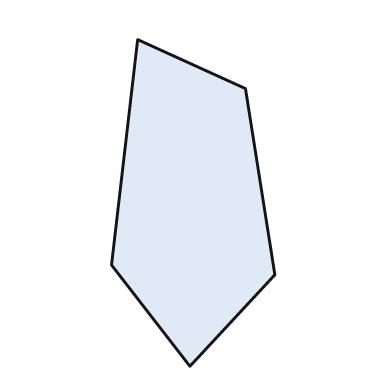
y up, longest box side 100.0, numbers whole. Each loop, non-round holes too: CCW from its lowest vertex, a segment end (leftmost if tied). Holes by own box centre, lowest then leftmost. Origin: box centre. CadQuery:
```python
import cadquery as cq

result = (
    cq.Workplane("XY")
    .moveTo(-1.0, -50.0)
    .lineTo(25.0, -22.0)
    .lineTo(16.0, 35.0)
    .lineTo(-17.0, 50.0)
    .lineTo(-25.0, -19.0)
    .close()
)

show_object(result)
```